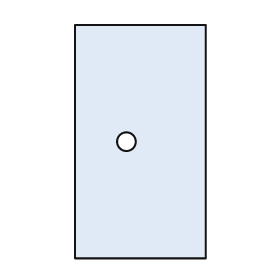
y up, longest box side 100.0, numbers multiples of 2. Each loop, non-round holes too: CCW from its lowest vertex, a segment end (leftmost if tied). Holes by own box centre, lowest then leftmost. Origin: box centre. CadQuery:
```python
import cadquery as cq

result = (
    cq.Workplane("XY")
    .moveTo(-28.0, -50.0)
    .lineTo(28.0, -50.0)
    .lineTo(28.0, 50.0)
    .lineTo(-28.0, 50.0)
    .close()
    .moveTo(-6.0, 0.0)
    .circle(4.0)
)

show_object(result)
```